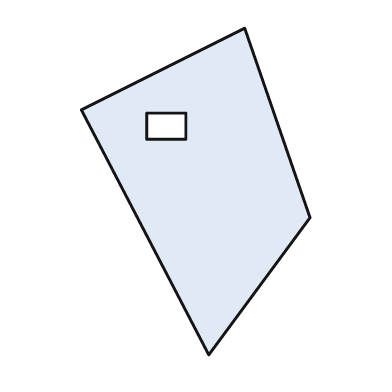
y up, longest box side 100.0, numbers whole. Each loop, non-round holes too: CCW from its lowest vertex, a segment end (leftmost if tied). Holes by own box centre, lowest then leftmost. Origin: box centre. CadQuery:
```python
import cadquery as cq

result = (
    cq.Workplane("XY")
    .moveTo(4.0, -50.0)
    .lineTo(35.0, -8.0)
    .lineTo(15.0, 50.0)
    .lineTo(-35.0, 25.0)
    .close()
    .moveTo(-15.0, 16.0)
    .lineTo(-3.0, 16.0)
    .lineTo(-3.0, 24.0)
    .lineTo(-15.0, 24.0)
    .close()
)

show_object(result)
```